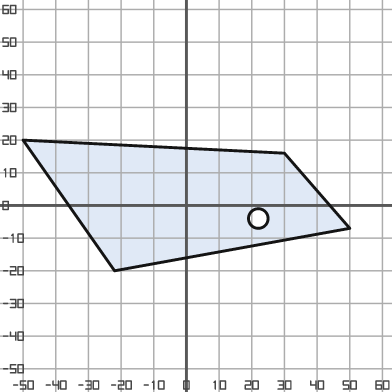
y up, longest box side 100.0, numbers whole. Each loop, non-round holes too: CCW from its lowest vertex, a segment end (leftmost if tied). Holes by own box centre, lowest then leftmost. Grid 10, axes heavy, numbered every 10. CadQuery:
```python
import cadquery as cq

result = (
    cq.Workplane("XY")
    .moveTo(-22.0, -20.0)
    .lineTo(50.0, -7.0)
    .lineTo(30.0, 16.0)
    .lineTo(-50.0, 20.0)
    .close()
    .moveTo(22.0, -4.0)
    .circle(3.0)
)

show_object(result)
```